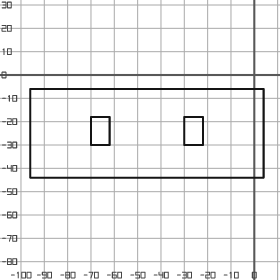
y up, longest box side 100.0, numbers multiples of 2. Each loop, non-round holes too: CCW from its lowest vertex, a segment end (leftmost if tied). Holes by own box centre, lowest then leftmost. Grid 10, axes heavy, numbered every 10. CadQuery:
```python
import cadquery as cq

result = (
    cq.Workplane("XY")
    .moveTo(-96.0, -44.0)
    .lineTo(4.0, -44.0)
    .lineTo(4.0, -6.0)
    .lineTo(-96.0, -6.0)
    .close()
    .moveTo(-70.0, -30.0)
    .lineTo(-62.0, -30.0)
    .lineTo(-62.0, -18.0)
    .lineTo(-70.0, -18.0)
    .close()
    .moveTo(-30.0, -30.0)
    .lineTo(-22.0, -30.0)
    .lineTo(-22.0, -18.0)
    .lineTo(-30.0, -18.0)
    .close()
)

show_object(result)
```